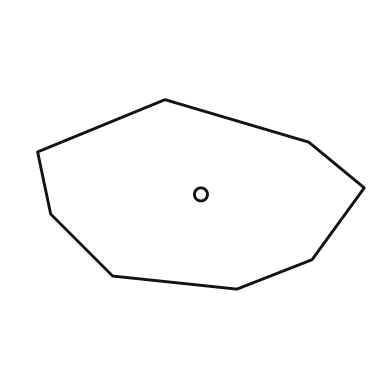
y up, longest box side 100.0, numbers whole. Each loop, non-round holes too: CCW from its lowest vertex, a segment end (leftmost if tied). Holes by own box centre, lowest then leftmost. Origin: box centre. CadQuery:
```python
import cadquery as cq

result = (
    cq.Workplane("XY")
    .moveTo(11.0, -29.0)
    .lineTo(34.0, -20.0)
    .lineTo(50.0, 2.0)
    .lineTo(33.0, 16.0)
    .lineTo(-11.0, 29.0)
    .lineTo(-50.0, 13.0)
    .lineTo(-46.0, -6.0)
    .lineTo(-27.0, -25.0)
    .close()
    .moveTo(0.0, 0.0)
    .circle(2.0)
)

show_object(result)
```